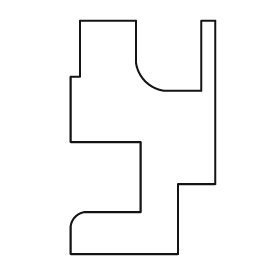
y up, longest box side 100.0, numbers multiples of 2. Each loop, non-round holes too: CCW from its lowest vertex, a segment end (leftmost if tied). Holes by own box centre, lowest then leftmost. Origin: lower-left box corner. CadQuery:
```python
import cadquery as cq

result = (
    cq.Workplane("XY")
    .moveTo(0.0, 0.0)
    .lineTo(46.0, 0.0)
    .lineTo(46.0, 30.0)
    .lineTo(62.0, 30.0)
    .lineTo(62.0, 100.0)
    .lineTo(56.0, 100.0)
    .lineTo(56.0, 70.0)
    .lineTo(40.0, 70.0)
    .threePointArc((32.0, 74.0), (28.0, 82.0))
    .lineTo(28.0, 100.0)
    .lineTo(4.0, 100.0)
    .lineTo(4.0, 76.0)
    .lineTo(0.0, 76.0)
    .lineTo(0.0, 48.0)
    .lineTo(30.0, 48.0)
    .lineTo(30.0, 18.0)
    .lineTo(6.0, 18.0)
    .threePointArc((2.0, 16.0), (0.0, 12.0))
    .close()
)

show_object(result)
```